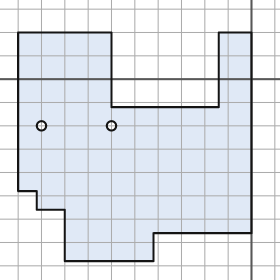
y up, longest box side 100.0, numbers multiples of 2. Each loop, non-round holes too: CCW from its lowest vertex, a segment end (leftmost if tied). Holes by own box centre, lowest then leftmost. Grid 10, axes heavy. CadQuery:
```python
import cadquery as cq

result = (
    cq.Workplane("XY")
    .moveTo(-80.0, -78.0)
    .lineTo(-42.0, -78.0)
    .lineTo(-42.0, -66.0)
    .lineTo(0.0, -66.0)
    .lineTo(0.0, 20.0)
    .lineTo(-14.0, 20.0)
    .lineTo(-14.0, -12.0)
    .lineTo(-60.0, -12.0)
    .lineTo(-60.0, 20.0)
    .lineTo(-100.0, 20.0)
    .lineTo(-100.0, -48.0)
    .lineTo(-92.0, -48.0)
    .lineTo(-92.0, -56.0)
    .lineTo(-80.0, -56.0)
    .close()
    .moveTo(-90.0, -20.0)
    .circle(2.0)
    .moveTo(-60.0, -20.0)
    .circle(2.0)
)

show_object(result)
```